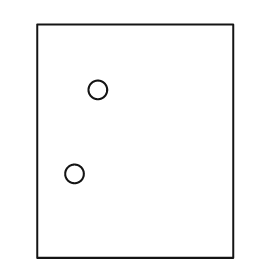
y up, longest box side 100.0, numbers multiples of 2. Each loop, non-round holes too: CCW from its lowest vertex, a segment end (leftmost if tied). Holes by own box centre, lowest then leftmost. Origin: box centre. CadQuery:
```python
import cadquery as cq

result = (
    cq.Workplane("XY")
    .moveTo(-42.0, -50.0)
    .lineTo(42.0, -50.0)
    .lineTo(42.0, 50.0)
    .lineTo(-42.0, 50.0)
    .close()
    .moveTo(-26.0, -14.0)
    .circle(4.0)
    .moveTo(-16.0, 22.0)
    .circle(4.0)
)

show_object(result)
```